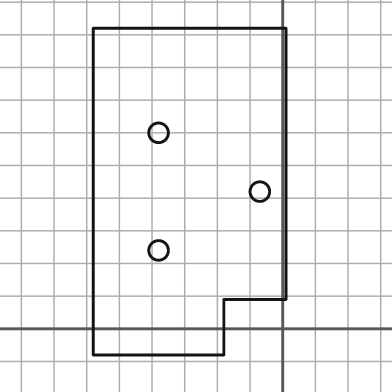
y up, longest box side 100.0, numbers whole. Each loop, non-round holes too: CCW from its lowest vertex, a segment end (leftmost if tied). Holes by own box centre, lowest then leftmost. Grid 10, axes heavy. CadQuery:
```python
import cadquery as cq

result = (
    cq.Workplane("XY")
    .moveTo(-58.0, -8.0)
    .lineTo(-18.0, -8.0)
    .lineTo(-18.0, 9.0)
    .lineTo(1.0, 9.0)
    .lineTo(1.0, 92.0)
    .lineTo(-58.0, 92.0)
    .close()
    .moveTo(-38.0, 24.0)
    .circle(3.0)
    .moveTo(-7.0, 42.0)
    .circle(3.0)
    .moveTo(-38.0, 60.0)
    .circle(3.0)
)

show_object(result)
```